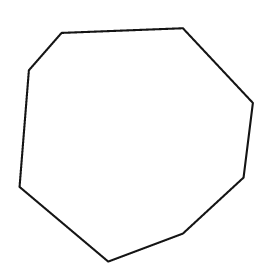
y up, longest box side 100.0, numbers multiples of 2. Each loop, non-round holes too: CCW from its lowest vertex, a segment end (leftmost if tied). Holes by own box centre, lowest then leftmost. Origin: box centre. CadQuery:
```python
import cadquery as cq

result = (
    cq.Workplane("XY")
    .moveTo(-12.0, -50.0)
    .lineTo(20.0, -38.0)
    .lineTo(46.0, -14.0)
    .lineTo(50.0, 18.0)
    .lineTo(20.0, 50.0)
    .lineTo(-32.0, 48.0)
    .lineTo(-46.0, 32.0)
    .lineTo(-50.0, -18.0)
    .close()
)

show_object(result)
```